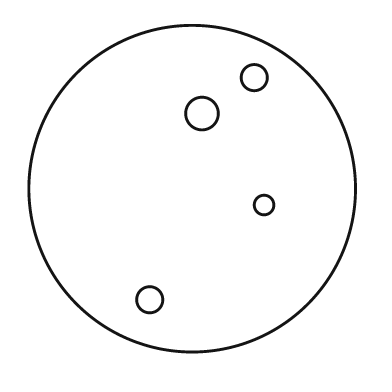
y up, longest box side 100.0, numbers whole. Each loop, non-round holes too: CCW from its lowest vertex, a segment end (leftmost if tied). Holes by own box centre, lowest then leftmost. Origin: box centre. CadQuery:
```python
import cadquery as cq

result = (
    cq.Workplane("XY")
    .moveTo(0.0, 0.0)
    .circle(50.0)
    .moveTo(-13.0, -34.0)
    .circle(4.0)
    .moveTo(22.0, -5.0)
    .circle(3.0)
    .moveTo(3.0, 23.0)
    .circle(5.0)
    .moveTo(19.0, 34.0)
    .circle(4.0)
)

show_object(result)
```